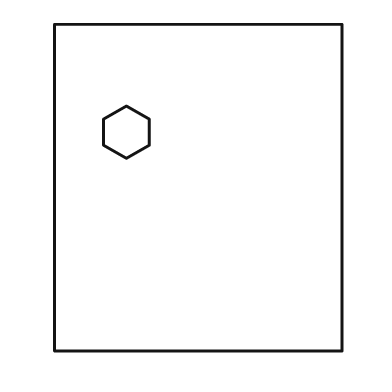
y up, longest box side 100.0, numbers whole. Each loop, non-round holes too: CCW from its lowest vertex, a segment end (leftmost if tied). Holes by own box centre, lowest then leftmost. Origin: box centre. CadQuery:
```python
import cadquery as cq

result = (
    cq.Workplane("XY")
    .moveTo(-44.0, -50.0)
    .lineTo(44.0, -50.0)
    .lineTo(44.0, 50.0)
    .lineTo(-44.0, 50.0)
    .close()
    .moveTo(-22.0, 9.0)
    .lineTo(-15.0, 13.0)
    .lineTo(-15.0, 21.0)
    .lineTo(-22.0, 25.0)
    .lineTo(-29.0, 21.0)
    .lineTo(-29.0, 13.0)
    .close()
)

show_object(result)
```